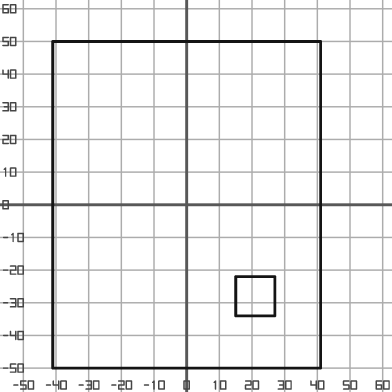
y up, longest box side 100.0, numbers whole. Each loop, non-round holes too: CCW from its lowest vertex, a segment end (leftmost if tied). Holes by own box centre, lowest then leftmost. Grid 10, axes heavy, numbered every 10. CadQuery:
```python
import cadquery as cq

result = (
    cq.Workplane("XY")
    .moveTo(-41.0, -50.0)
    .lineTo(41.0, -50.0)
    .lineTo(41.0, 50.0)
    .lineTo(-41.0, 50.0)
    .close()
    .moveTo(15.0, -34.0)
    .lineTo(27.0, -34.0)
    .lineTo(27.0, -22.0)
    .lineTo(15.0, -22.0)
    .close()
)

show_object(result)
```